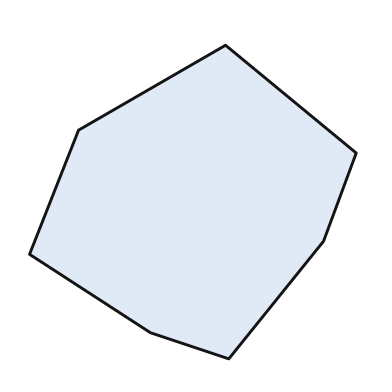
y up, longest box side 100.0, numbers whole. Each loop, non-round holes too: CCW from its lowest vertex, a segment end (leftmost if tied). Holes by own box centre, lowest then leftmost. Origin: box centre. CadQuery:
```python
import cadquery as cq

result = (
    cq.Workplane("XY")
    .moveTo(11.0, -48.0)
    .lineTo(40.0, -12.0)
    .lineTo(50.0, 15.0)
    .lineTo(10.0, 48.0)
    .lineTo(-35.0, 22.0)
    .lineTo(-50.0, -16.0)
    .lineTo(-13.0, -40.0)
    .close()
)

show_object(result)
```